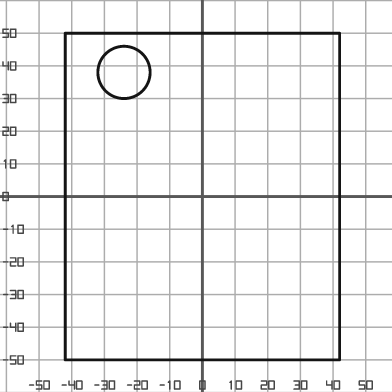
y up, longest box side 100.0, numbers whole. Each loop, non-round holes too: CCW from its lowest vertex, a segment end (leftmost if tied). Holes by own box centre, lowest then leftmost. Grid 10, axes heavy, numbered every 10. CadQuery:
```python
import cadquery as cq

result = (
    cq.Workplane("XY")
    .moveTo(-42.0, -50.0)
    .lineTo(42.0, -50.0)
    .lineTo(42.0, 50.0)
    .lineTo(-42.0, 50.0)
    .close()
    .moveTo(-24.0, 38.0)
    .circle(8.0)
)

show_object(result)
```